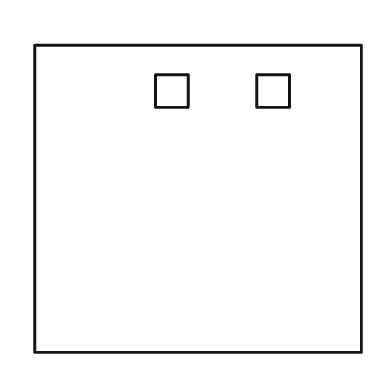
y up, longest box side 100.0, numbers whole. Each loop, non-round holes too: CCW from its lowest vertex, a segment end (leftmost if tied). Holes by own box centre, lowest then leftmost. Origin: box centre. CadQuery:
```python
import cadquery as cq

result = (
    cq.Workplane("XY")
    .moveTo(-50.0, -47.0)
    .lineTo(50.0, -47.0)
    .lineTo(50.0, 47.0)
    .lineTo(-50.0, 47.0)
    .close()
    .moveTo(-13.0, 28.0)
    .lineTo(-3.0, 28.0)
    .lineTo(-3.0, 38.0)
    .lineTo(-13.0, 38.0)
    .close()
    .moveTo(18.0, 28.0)
    .lineTo(28.0, 28.0)
    .lineTo(28.0, 38.0)
    .lineTo(18.0, 38.0)
    .close()
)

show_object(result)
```